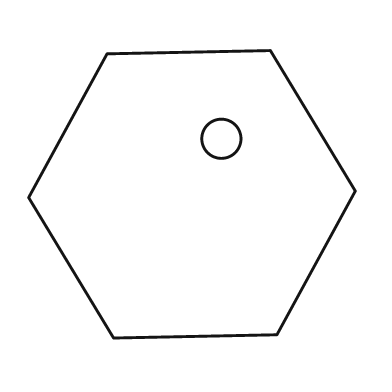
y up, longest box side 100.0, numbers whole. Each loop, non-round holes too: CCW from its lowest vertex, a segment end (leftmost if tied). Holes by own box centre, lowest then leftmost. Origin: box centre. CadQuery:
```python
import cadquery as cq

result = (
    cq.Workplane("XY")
    .moveTo(-24.0, -44.0)
    .lineTo(26.0, -43.0)
    .lineTo(50.0, 1.0)
    .lineTo(24.0, 44.0)
    .lineTo(-26.0, 43.0)
    .lineTo(-50.0, -1.0)
    .close()
    .moveTo(9.0, 17.0)
    .circle(6.0)
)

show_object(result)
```